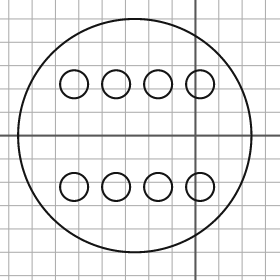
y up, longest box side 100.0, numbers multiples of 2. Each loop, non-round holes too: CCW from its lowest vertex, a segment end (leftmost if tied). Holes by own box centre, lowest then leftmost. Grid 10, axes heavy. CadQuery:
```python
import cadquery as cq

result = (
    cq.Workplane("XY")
    .moveTo(-26.0, 0.0)
    .circle(50.0)
    .moveTo(-52.0, -22.0)
    .circle(6.0)
    .moveTo(-34.0, -22.0)
    .circle(6.0)
    .moveTo(-16.0, -22.0)
    .circle(6.0)
    .moveTo(2.0, -22.0)
    .circle(6.0)
    .moveTo(-52.0, 22.0)
    .circle(6.0)
    .moveTo(-34.0, 22.0)
    .circle(6.0)
    .moveTo(-16.0, 22.0)
    .circle(6.0)
    .moveTo(2.0, 22.0)
    .circle(6.0)
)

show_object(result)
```